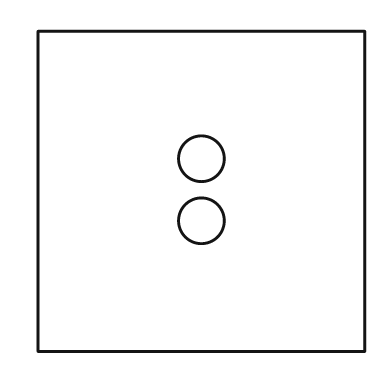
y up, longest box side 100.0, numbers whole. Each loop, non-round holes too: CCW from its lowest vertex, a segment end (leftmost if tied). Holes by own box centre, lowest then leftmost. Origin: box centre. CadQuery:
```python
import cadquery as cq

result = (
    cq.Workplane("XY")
    .moveTo(-50.0, -49.0)
    .lineTo(50.0, -49.0)
    .lineTo(50.0, 49.0)
    .lineTo(-50.0, 49.0)
    .close()
    .moveTo(0.0, -9.0)
    .circle(7.0)
    .moveTo(0.0, 10.0)
    .circle(7.0)
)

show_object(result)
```